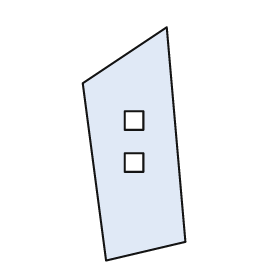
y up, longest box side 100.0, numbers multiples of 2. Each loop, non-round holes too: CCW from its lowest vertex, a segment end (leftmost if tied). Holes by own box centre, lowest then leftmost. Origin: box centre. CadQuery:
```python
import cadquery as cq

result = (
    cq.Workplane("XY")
    .moveTo(-12.0, -50.0)
    .lineTo(22.0, -42.0)
    .lineTo(14.0, 50.0)
    .lineTo(-22.0, 26.0)
    .close()
    .moveTo(-4.0, -12.0)
    .lineTo(4.0, -12.0)
    .lineTo(4.0, -4.0)
    .lineTo(-4.0, -4.0)
    .close()
    .moveTo(-4.0, 6.0)
    .lineTo(4.0, 6.0)
    .lineTo(4.0, 14.0)
    .lineTo(-4.0, 14.0)
    .close()
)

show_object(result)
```